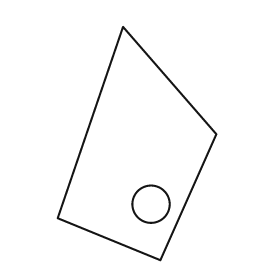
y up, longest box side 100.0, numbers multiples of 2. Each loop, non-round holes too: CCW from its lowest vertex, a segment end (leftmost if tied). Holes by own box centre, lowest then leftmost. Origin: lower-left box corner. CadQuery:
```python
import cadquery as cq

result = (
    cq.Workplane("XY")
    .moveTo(44.0, 0.0)
    .lineTo(68.0, 54.0)
    .lineTo(28.0, 100.0)
    .lineTo(0.0, 18.0)
    .close()
    .moveTo(40.0, 24.0)
    .circle(8.0)
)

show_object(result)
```